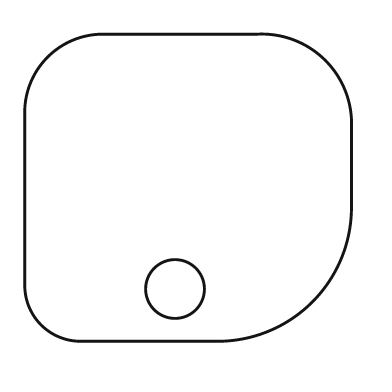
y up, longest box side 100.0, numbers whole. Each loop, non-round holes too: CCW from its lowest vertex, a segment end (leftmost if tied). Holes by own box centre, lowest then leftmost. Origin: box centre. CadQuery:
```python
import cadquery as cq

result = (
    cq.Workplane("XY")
    .moveTo(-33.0, -47.0)
    .lineTo(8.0, -47.0)
    .threePointArc((38.0, -35.0), (50.0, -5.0))
    .lineTo(50.0, 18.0)
    .threePointArc((42.0, 39.0), (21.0, 47.0))
    .lineTo(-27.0, 47.0)
    .threePointArc((-43.0, 40.0), (-50.0, 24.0))
    .lineTo(-50.0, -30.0)
    .threePointArc((-45.0, -42.0), (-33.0, -47.0))
    .close()
    .moveTo(-4.0, -31.0)
    .circle(9.0)
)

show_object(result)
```